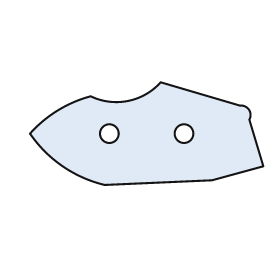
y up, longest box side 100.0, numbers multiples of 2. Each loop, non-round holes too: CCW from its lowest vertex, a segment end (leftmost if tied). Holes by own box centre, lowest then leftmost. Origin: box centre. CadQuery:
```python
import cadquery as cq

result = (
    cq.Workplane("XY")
    .moveTo(-18.0, -22.0)
    .lineTo(28.0, -20.0)
    .lineTo(50.0, -14.0)
    .lineTo(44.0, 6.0)
    .threePointArc((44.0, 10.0), (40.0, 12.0))
    .lineTo(6.0, 22.0)
    .threePointArc((-8.0, 14.0), (-24.0, 16.0))
    .threePointArc((-38.0, 10.0), (-50.0, 0.0))
    .threePointArc((-36.0, -14.0), (-18.0, -22.0))
    .close()
    .moveTo(-16.0, 0.0)
    .circle(4.0)
    .moveTo(16.0, 0.0)
    .circle(4.0)
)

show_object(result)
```